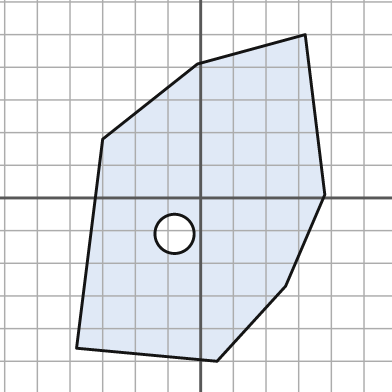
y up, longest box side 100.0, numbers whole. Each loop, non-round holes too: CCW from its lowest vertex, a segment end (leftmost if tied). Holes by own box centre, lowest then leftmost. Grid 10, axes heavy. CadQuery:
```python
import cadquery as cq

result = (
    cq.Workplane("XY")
    .moveTo(5.0, -50.0)
    .lineTo(26.0, -27.0)
    .lineTo(38.0, 1.0)
    .lineTo(32.0, 50.0)
    .lineTo(-1.0, 41.0)
    .lineTo(-30.0, 18.0)
    .lineTo(-38.0, -46.0)
    .close()
    .moveTo(-8.0, -11.0)
    .circle(6.0)
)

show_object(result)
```